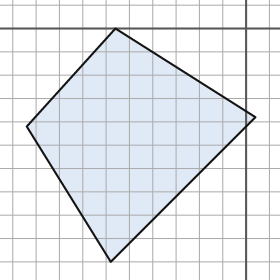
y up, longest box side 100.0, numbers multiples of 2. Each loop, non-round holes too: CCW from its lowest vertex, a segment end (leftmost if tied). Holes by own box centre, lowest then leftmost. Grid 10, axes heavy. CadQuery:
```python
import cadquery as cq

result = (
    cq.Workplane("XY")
    .moveTo(-58.0, -100.0)
    .lineTo(4.0, -38.0)
    .lineTo(-56.0, 0.0)
    .lineTo(-94.0, -42.0)
    .close()
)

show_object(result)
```